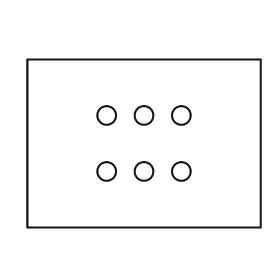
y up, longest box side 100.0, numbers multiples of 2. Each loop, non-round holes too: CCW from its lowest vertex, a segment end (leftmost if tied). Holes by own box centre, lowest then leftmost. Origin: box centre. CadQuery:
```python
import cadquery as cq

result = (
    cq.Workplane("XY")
    .moveTo(-50.0, -36.0)
    .lineTo(50.0, -36.0)
    .lineTo(50.0, 36.0)
    .lineTo(-50.0, 36.0)
    .close()
    .moveTo(-16.0, -12.0)
    .circle(4.0)
    .moveTo(0.0, -12.0)
    .circle(4.0)
    .moveTo(16.0, -12.0)
    .circle(4.0)
    .moveTo(-16.0, 12.0)
    .circle(4.0)
    .moveTo(0.0, 12.0)
    .circle(4.0)
    .moveTo(16.0, 12.0)
    .circle(4.0)
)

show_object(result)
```